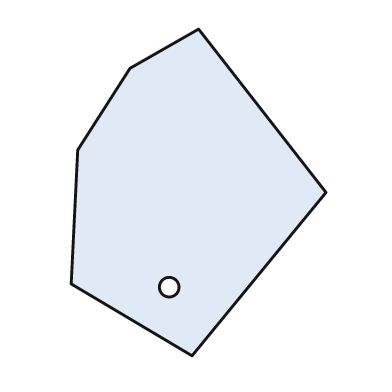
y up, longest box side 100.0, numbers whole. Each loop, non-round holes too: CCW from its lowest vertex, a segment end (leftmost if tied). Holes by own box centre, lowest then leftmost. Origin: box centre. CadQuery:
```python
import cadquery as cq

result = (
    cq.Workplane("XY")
    .moveTo(-2.0, -50.0)
    .lineTo(39.0, 0.0)
    .lineTo(0.0, 50.0)
    .lineTo(-21.0, 38.0)
    .lineTo(-37.0, 13.0)
    .lineTo(-39.0, -28.0)
    .close()
    .moveTo(-9.0, -29.0)
    .circle(3.0)
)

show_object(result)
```